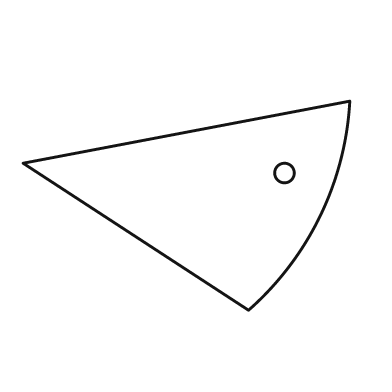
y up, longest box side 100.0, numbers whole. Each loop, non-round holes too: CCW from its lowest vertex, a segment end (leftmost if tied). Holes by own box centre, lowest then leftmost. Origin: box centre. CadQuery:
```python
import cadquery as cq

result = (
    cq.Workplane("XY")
    .moveTo(19.0, -32.0)
    .threePointArc((41.0, -3.0), (50.0, 32.0))
    .lineTo(-50.0, 13.0)
    .close()
    .moveTo(30.0, 10.0)
    .circle(3.0)
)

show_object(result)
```